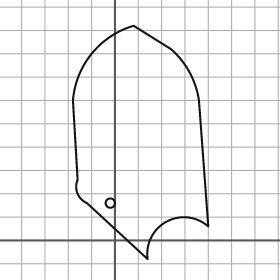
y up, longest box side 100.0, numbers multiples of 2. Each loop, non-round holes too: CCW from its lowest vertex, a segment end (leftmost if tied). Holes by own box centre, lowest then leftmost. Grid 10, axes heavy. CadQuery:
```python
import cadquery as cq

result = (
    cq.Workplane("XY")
    .moveTo(14.0, -8.0)
    .threePointArc((22.0, 8.0), (40.0, 6.0))
    .lineTo(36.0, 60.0)
    .threePointArc((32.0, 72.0), (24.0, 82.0))
    .lineTo(8.0, 92.0)
    .threePointArc((-10.0, 80.0), (-18.0, 60.0))
    .lineTo(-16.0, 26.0)
    .threePointArc((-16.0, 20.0), (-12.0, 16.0))
    .close()
    .moveTo(-2.0, 16.0)
    .circle(2.0)
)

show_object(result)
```